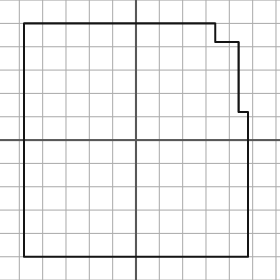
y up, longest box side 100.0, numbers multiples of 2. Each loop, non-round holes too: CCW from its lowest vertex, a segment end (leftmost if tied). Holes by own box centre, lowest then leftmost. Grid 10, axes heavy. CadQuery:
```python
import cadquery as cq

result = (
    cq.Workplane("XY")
    .moveTo(-48.0, -50.0)
    .lineTo(48.0, -50.0)
    .lineTo(48.0, 12.0)
    .lineTo(44.0, 12.0)
    .lineTo(44.0, 42.0)
    .lineTo(34.0, 42.0)
    .lineTo(34.0, 50.0)
    .lineTo(-48.0, 50.0)
    .close()
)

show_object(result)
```